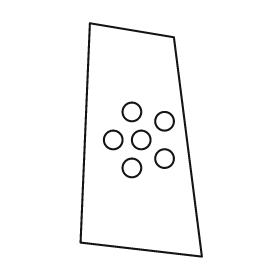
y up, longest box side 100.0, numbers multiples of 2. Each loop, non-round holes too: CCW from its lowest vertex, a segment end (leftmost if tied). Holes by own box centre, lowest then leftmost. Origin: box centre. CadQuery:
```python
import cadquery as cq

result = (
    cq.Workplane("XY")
    .moveTo(26.0, -50.0)
    .lineTo(14.0, 44.0)
    .lineTo(-22.0, 50.0)
    .lineTo(-26.0, -44.0)
    .close()
    .moveTo(-4.0, -12.0)
    .circle(4.0)
    .moveTo(10.0, -8.0)
    .circle(4.0)
    .moveTo(-12.0, 0.0)
    .circle(4.0)
    .moveTo(0.0, 0.0)
    .circle(4.0)
    .moveTo(10.0, 8.0)
    .circle(4.0)
    .moveTo(-4.0, 12.0)
    .circle(4.0)
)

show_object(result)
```